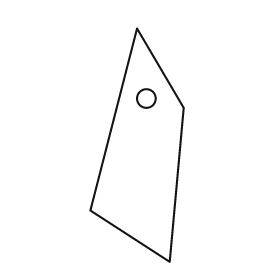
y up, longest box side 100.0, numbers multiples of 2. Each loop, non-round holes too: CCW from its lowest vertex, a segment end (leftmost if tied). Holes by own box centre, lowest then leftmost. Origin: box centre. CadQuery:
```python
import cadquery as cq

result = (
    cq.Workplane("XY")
    .moveTo(14.0, -50.0)
    .lineTo(20.0, 16.0)
    .lineTo(0.0, 50.0)
    .lineTo(-20.0, -28.0)
    .close()
    .moveTo(4.0, 20.0)
    .circle(4.0)
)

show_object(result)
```